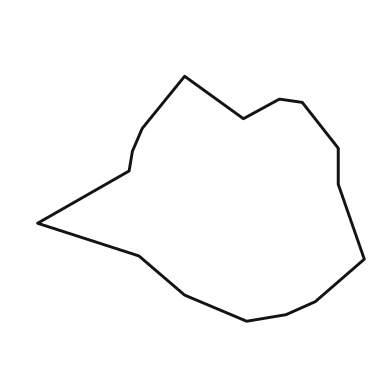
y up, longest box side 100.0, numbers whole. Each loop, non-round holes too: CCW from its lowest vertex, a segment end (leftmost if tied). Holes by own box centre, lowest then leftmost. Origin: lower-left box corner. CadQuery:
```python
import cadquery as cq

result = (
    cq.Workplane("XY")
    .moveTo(64.0, 0.0)
    .lineTo(76.0, 2.0)
    .lineTo(85.0, 6.0)
    .lineTo(100.0, 19.0)
    .lineTo(92.0, 42.0)
    .lineTo(92.0, 53.0)
    .lineTo(81.0, 67.0)
    .lineTo(74.0, 68.0)
    .lineTo(63.0, 62.0)
    .lineTo(45.0, 75.0)
    .lineTo(32.0, 59.0)
    .lineTo(29.0, 52.0)
    .lineTo(28.0, 46.0)
    .lineTo(0.0, 30.0)
    .lineTo(31.0, 20.0)
    .lineTo(45.0, 8.0)
    .close()
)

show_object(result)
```